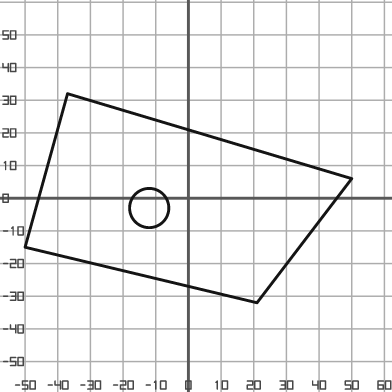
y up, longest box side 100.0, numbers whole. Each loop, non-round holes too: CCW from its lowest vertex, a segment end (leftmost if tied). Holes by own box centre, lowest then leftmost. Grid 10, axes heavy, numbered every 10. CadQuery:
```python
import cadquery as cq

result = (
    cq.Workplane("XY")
    .moveTo(21.0, -32.0)
    .lineTo(50.0, 6.0)
    .lineTo(-37.0, 32.0)
    .lineTo(-50.0, -15.0)
    .close()
    .moveTo(-12.0, -3.0)
    .circle(6.0)
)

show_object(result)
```